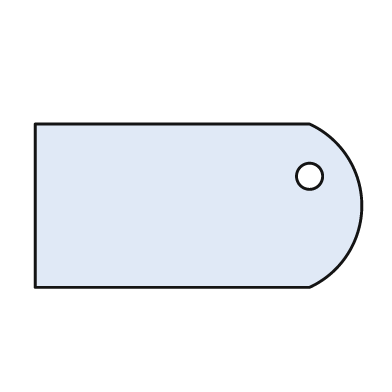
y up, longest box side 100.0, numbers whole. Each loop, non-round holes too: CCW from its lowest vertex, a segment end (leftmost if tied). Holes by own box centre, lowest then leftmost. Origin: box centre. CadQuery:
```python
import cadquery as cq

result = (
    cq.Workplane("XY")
    .moveTo(-50.0, -25.0)
    .lineTo(34.0, -25.0)
    .threePointArc((50.0, 0.0), (34.0, 25.0))
    .lineTo(-50.0, 25.0)
    .close()
    .moveTo(34.0, 9.0)
    .circle(4.0)
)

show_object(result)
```